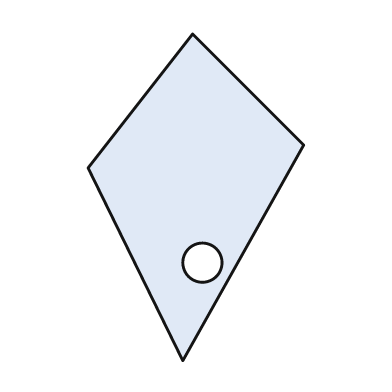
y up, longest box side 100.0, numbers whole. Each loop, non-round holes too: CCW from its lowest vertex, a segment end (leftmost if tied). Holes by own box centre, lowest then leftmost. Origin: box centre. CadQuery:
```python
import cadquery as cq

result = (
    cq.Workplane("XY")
    .moveTo(-4.0, -50.0)
    .lineTo(33.0, 16.0)
    .lineTo(-1.0, 50.0)
    .lineTo(-33.0, 9.0)
    .close()
    .moveTo(2.0, -20.0)
    .circle(6.0)
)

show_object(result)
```